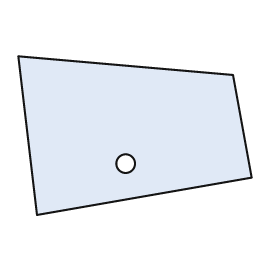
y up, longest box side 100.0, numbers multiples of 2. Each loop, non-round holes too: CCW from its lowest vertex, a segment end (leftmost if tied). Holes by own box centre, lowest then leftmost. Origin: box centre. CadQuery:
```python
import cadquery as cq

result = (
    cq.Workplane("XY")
    .moveTo(-42.0, -34.0)
    .lineTo(50.0, -18.0)
    .lineTo(42.0, 26.0)
    .lineTo(-50.0, 34.0)
    .close()
    .moveTo(-4.0, -12.0)
    .circle(4.0)
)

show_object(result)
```